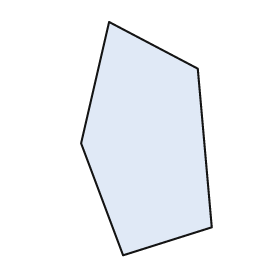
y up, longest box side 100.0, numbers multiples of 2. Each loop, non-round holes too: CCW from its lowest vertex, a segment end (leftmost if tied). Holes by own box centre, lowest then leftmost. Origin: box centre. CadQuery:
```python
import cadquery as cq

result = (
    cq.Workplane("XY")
    .moveTo(-10.0, -50.0)
    .lineTo(28.0, -38.0)
    .lineTo(22.0, 30.0)
    .lineTo(-16.0, 50.0)
    .lineTo(-28.0, -2.0)
    .close()
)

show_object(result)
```